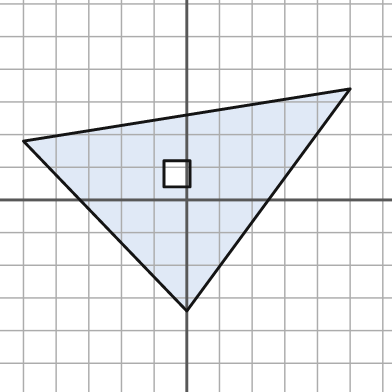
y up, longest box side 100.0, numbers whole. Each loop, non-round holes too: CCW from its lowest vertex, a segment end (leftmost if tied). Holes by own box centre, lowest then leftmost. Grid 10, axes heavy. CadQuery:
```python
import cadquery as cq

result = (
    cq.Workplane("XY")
    .moveTo(0.0, -34.0)
    .lineTo(50.0, 34.0)
    .lineTo(-50.0, 18.0)
    .close()
    .moveTo(-7.0, 4.0)
    .lineTo(1.0, 4.0)
    .lineTo(1.0, 12.0)
    .lineTo(-7.0, 12.0)
    .close()
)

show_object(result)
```